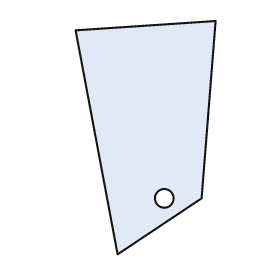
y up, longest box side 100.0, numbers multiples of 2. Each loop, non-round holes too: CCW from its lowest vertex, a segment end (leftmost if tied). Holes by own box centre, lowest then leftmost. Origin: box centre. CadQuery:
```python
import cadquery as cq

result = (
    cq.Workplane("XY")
    .moveTo(-12.0, -50.0)
    .lineTo(24.0, -26.0)
    .lineTo(30.0, 50.0)
    .lineTo(-30.0, 46.0)
    .close()
    .moveTo(8.0, -26.0)
    .circle(4.0)
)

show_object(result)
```